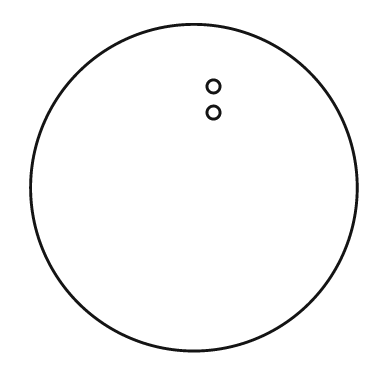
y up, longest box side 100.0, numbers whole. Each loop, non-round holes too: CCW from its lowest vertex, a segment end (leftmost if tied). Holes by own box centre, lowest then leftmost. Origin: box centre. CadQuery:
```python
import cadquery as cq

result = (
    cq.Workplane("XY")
    .moveTo(0.0, 0.0)
    .circle(50.0)
    .moveTo(6.0, 23.0)
    .circle(2.0)
    .moveTo(6.0, 31.0)
    .circle(2.0)
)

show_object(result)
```